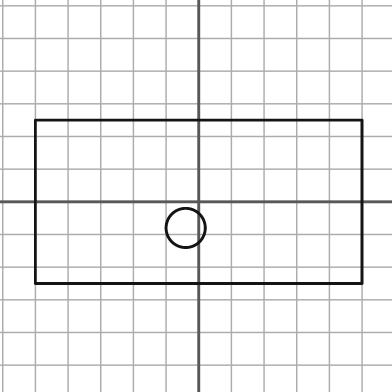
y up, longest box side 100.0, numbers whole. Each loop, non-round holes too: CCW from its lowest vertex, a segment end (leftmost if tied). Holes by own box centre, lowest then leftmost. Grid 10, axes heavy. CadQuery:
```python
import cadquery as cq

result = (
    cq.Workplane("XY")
    .moveTo(-50.0, -25.0)
    .lineTo(50.0, -25.0)
    .lineTo(50.0, 25.0)
    .lineTo(-50.0, 25.0)
    .close()
    .moveTo(-4.0, -8.0)
    .circle(6.0)
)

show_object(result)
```